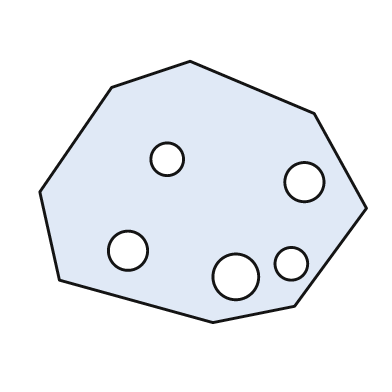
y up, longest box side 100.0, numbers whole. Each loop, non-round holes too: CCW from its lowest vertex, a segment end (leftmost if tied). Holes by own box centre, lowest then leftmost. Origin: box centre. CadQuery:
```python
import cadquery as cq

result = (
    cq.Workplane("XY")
    .moveTo(3.0, -40.0)
    .lineTo(28.0, -35.0)
    .lineTo(50.0, -5.0)
    .lineTo(34.0, 24.0)
    .lineTo(-4.0, 40.0)
    .lineTo(-28.0, 32.0)
    .lineTo(-50.0, 0.0)
    .lineTo(-44.0, -27.0)
    .close()
    .moveTo(10.0, -26.0)
    .circle(7.0)
    .moveTo(27.0, -22.0)
    .circle(5.0)
    .moveTo(-23.0, -18.0)
    .circle(6.0)
    .moveTo(31.0, 3.0)
    .circle(6.0)
    .moveTo(-11.0, 10.0)
    .circle(5.0)
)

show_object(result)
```